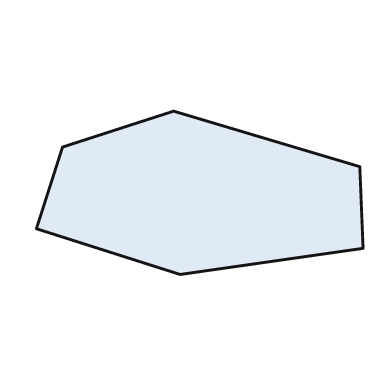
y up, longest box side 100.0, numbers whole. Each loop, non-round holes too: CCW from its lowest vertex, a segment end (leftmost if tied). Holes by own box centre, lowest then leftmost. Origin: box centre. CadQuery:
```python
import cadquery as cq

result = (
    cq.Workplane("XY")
    .moveTo(-6.0, -25.0)
    .lineTo(50.0, -17.0)
    .lineTo(49.0, 8.0)
    .lineTo(-8.0, 25.0)
    .lineTo(-42.0, 14.0)
    .lineTo(-50.0, -11.0)
    .close()
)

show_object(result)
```